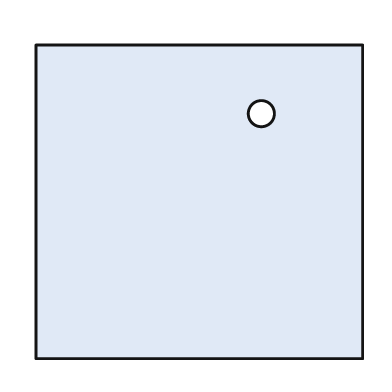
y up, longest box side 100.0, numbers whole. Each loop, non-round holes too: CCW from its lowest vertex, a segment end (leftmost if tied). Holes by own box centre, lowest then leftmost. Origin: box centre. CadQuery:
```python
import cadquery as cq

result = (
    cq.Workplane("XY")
    .moveTo(-50.0, -48.0)
    .lineTo(50.0, -48.0)
    .lineTo(50.0, 48.0)
    .lineTo(-50.0, 48.0)
    .close()
    .moveTo(19.0, 27.0)
    .circle(4.0)
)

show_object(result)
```